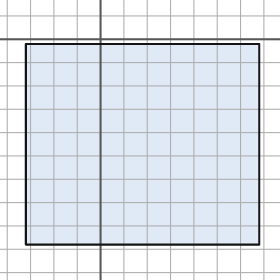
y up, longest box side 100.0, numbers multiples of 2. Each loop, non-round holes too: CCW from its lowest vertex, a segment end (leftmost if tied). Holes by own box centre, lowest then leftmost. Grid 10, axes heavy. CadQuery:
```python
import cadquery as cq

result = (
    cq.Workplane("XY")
    .moveTo(-32.0, -88.0)
    .lineTo(68.0, -88.0)
    .lineTo(68.0, -2.0)
    .lineTo(-32.0, -2.0)
    .close()
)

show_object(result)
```